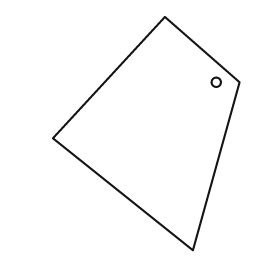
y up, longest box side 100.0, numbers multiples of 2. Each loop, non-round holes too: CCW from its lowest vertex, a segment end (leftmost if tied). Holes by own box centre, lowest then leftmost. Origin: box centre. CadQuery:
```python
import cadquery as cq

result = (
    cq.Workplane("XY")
    .moveTo(20.0, -50.0)
    .lineTo(40.0, 22.0)
    .lineTo(8.0, 50.0)
    .lineTo(-40.0, -2.0)
    .close()
    .moveTo(30.0, 22.0)
    .circle(2.0)
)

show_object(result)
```